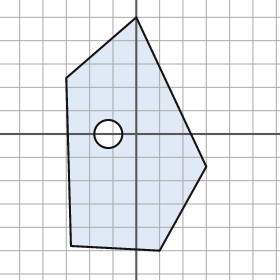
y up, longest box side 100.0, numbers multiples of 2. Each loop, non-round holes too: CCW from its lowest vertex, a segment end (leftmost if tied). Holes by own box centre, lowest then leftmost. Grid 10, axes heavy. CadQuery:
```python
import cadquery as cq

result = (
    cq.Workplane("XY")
    .moveTo(10.0, -50.0)
    .lineTo(30.0, -14.0)
    .lineTo(0.0, 50.0)
    .lineTo(-30.0, 24.0)
    .lineTo(-28.0, -48.0)
    .close()
    .moveTo(-12.0, 0.0)
    .circle(6.0)
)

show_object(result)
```